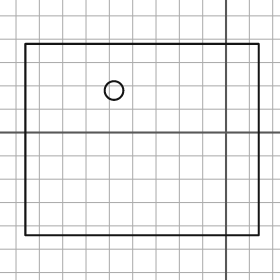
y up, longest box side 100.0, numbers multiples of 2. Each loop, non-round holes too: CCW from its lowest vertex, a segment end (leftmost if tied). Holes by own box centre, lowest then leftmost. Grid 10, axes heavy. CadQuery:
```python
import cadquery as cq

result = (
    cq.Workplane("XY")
    .moveTo(-86.0, -44.0)
    .lineTo(14.0, -44.0)
    .lineTo(14.0, 38.0)
    .lineTo(-86.0, 38.0)
    .close()
    .moveTo(-48.0, 18.0)
    .circle(4.0)
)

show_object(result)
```